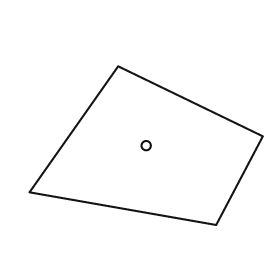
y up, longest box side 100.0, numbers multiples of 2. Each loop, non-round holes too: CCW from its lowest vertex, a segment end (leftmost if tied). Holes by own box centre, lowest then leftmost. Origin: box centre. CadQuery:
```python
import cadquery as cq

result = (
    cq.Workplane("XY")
    .moveTo(30.0, -34.0)
    .lineTo(50.0, 4.0)
    .lineTo(-12.0, 34.0)
    .lineTo(-50.0, -20.0)
    .close()
    .moveTo(0.0, 0.0)
    .circle(2.0)
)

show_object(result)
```